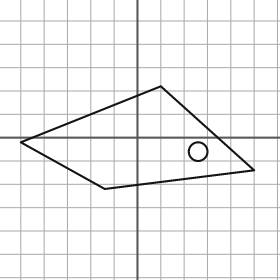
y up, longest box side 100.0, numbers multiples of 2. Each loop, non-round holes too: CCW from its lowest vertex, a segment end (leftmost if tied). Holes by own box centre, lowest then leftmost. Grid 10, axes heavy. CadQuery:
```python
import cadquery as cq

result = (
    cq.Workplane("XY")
    .moveTo(-14.0, -22.0)
    .lineTo(50.0, -14.0)
    .lineTo(10.0, 22.0)
    .lineTo(-50.0, -2.0)
    .close()
    .moveTo(26.0, -6.0)
    .circle(4.0)
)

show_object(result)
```